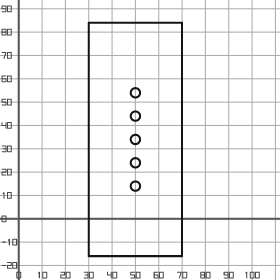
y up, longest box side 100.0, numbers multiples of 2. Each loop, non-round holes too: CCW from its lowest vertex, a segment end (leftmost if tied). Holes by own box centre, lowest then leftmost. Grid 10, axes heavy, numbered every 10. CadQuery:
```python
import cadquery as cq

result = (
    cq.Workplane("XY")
    .moveTo(30.0, -16.0)
    .lineTo(70.0, -16.0)
    .lineTo(70.0, 84.0)
    .lineTo(30.0, 84.0)
    .close()
    .moveTo(50.0, 14.0)
    .circle(2.0)
    .moveTo(50.0, 24.0)
    .circle(2.0)
    .moveTo(50.0, 34.0)
    .circle(2.0)
    .moveTo(50.0, 44.0)
    .circle(2.0)
    .moveTo(50.0, 54.0)
    .circle(2.0)
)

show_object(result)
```